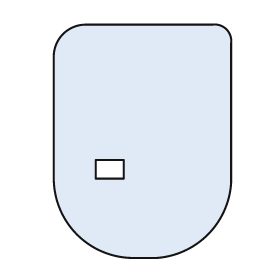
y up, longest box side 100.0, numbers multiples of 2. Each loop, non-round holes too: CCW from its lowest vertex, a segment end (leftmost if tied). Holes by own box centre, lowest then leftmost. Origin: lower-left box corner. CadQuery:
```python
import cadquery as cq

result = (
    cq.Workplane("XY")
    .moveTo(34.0, 0.0)
    .lineTo(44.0, 0.0)
    .threePointArc((66.0, 10.0), (76.0, 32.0))
    .lineTo(76.0, 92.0)
    .threePointArc((74.0, 98.0), (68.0, 100.0))
    .lineTo(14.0, 100.0)
    .threePointArc((4.0, 96.0), (0.0, 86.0))
    .lineTo(0.0, 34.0)
    .threePointArc((10.0, 10.0), (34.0, 0.0))
    .close()
    .moveTo(18.0, 34.0)
    .lineTo(30.0, 34.0)
    .lineTo(30.0, 42.0)
    .lineTo(18.0, 42.0)
    .close()
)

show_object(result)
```